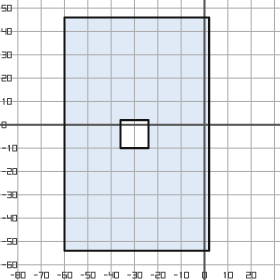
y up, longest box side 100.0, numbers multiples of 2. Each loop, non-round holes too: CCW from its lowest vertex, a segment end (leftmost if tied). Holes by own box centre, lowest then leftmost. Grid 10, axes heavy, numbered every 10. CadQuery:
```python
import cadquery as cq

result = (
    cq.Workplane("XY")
    .moveTo(-60.0, -54.0)
    .lineTo(2.0, -54.0)
    .lineTo(2.0, 46.0)
    .lineTo(-60.0, 46.0)
    .close()
    .moveTo(-36.0, -10.0)
    .lineTo(-24.0, -10.0)
    .lineTo(-24.0, 2.0)
    .lineTo(-36.0, 2.0)
    .close()
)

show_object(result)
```